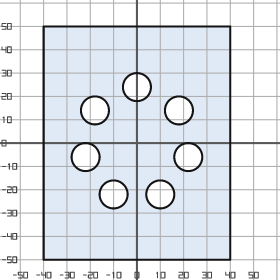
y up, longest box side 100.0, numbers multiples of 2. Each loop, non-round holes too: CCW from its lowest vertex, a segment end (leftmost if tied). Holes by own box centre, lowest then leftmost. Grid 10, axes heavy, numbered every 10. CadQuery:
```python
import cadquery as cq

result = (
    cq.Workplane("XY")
    .moveTo(-40.0, -50.0)
    .lineTo(40.0, -50.0)
    .lineTo(40.0, 50.0)
    .lineTo(-40.0, 50.0)
    .close()
    .moveTo(-10.0, -22.0)
    .circle(6.0)
    .moveTo(10.0, -22.0)
    .circle(6.0)
    .moveTo(-22.0, -6.0)
    .circle(6.0)
    .moveTo(22.0, -6.0)
    .circle(6.0)
    .moveTo(-18.0, 14.0)
    .circle(6.0)
    .moveTo(18.0, 14.0)
    .circle(6.0)
    .moveTo(0.0, 24.0)
    .circle(6.0)
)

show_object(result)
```